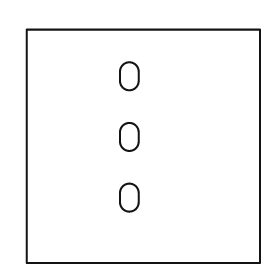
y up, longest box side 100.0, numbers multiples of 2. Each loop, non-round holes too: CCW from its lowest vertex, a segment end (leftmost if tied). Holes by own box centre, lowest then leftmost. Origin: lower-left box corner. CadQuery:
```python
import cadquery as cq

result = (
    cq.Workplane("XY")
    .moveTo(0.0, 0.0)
    .lineTo(100.0, 0.0)
    .lineTo(100.0, 100.0)
    .lineTo(0.0, 100.0)
    .close()
    .moveTo(40.0, 26.0)
    .threePointArc((44.0, 22.0), (48.0, 26.0))
    .lineTo(48.0, 30.0)
    .threePointArc((44.0, 34.0), (40.0, 30.0))
    .close()
    .moveTo(40.0, 52.0)
    .threePointArc((44.0, 48.0), (48.0, 52.0))
    .lineTo(48.0, 56.0)
    .threePointArc((44.0, 60.0), (40.0, 56.0))
    .close()
    .moveTo(40.0, 78.0)
    .threePointArc((44.0, 74.0), (48.0, 78.0))
    .lineTo(48.0, 82.0)
    .threePointArc((44.0, 86.0), (40.0, 82.0))
    .close()
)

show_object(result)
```